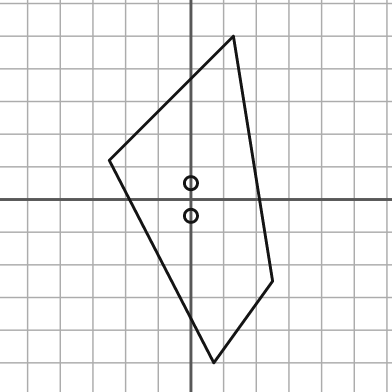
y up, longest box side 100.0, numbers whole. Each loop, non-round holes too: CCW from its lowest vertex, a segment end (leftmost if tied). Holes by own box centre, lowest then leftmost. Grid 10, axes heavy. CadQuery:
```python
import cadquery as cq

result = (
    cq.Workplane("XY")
    .moveTo(7.0, -50.0)
    .lineTo(25.0, -25.0)
    .lineTo(13.0, 50.0)
    .lineTo(-25.0, 12.0)
    .close()
    .moveTo(0.0, -5.0)
    .circle(2.0)
    .moveTo(0.0, 5.0)
    .circle(2.0)
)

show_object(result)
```